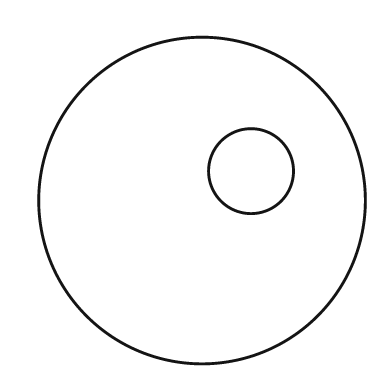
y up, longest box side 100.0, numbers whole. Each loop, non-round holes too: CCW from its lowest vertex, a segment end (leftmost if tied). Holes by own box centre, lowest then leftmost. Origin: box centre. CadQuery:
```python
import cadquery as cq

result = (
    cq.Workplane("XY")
    .moveTo(0.0, 0.0)
    .circle(50.0)
    .moveTo(15.0, 9.0)
    .circle(13.0)
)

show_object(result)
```